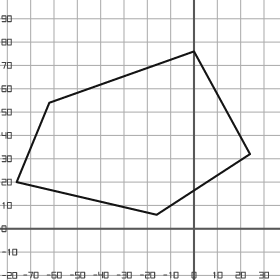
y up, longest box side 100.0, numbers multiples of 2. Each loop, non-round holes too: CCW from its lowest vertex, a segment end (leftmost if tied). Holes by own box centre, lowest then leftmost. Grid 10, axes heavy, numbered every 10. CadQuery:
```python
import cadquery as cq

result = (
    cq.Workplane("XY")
    .moveTo(-16.0, 6.0)
    .lineTo(24.0, 32.0)
    .lineTo(0.0, 76.0)
    .lineTo(-62.0, 54.0)
    .lineTo(-76.0, 20.0)
    .close()
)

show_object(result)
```